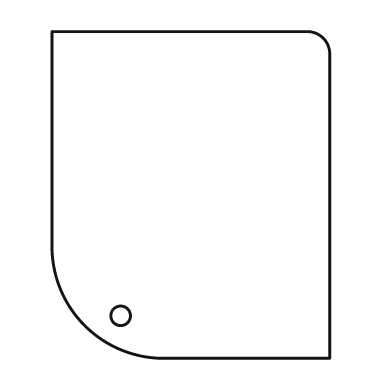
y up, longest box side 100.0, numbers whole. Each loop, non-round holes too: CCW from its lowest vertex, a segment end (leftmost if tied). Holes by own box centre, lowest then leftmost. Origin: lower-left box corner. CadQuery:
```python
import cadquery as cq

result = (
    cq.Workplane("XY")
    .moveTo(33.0, 0.0)
    .lineTo(85.0, 0.0)
    .lineTo(85.0, 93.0)
    .threePointArc((83.0, 98.0), (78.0, 100.0))
    .lineTo(0.0, 100.0)
    .lineTo(0.0, 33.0)
    .threePointArc((10.0, 10.0), (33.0, 0.0))
    .close()
    .moveTo(21.0, 13.0)
    .circle(3.0)
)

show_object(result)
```